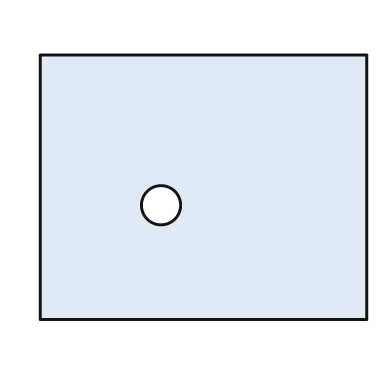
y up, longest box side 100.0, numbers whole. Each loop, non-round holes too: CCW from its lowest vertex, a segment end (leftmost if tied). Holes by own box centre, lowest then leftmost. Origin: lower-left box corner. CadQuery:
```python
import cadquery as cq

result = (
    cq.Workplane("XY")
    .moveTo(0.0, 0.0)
    .lineTo(100.0, 0.0)
    .lineTo(100.0, 81.0)
    .lineTo(0.0, 81.0)
    .close()
    .moveTo(37.0, 35.0)
    .circle(6.0)
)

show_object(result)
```